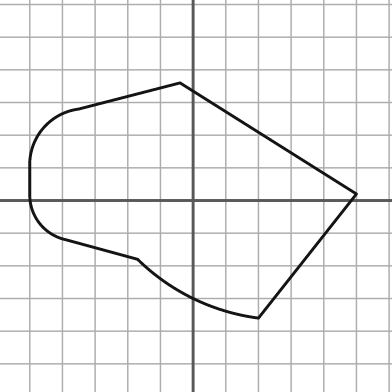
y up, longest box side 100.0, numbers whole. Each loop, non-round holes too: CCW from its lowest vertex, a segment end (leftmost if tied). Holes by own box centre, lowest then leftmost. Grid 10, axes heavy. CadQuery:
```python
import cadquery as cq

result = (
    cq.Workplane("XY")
    .moveTo(20.0, -36.0)
    .lineTo(50.0, 2.0)
    .lineTo(-4.0, 36.0)
    .lineTo(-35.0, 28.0)
    .threePointArc((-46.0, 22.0), (-50.0, 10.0))
    .lineTo(-50.0, 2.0)
    .threePointArc((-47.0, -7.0), (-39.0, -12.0))
    .lineTo(-17.0, -18.0)
    .threePointArc((0.0, -30.0), (20.0, -36.0))
    .close()
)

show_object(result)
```